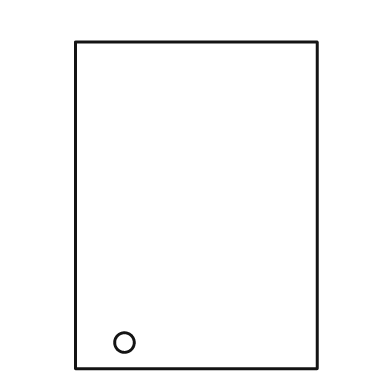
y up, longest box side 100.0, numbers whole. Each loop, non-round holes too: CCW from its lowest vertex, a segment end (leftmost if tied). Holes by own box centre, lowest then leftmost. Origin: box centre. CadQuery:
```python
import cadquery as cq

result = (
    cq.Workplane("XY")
    .moveTo(-37.0, -50.0)
    .lineTo(37.0, -50.0)
    .lineTo(37.0, 50.0)
    .lineTo(-37.0, 50.0)
    .close()
    .moveTo(-22.0, -42.0)
    .circle(3.0)
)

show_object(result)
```